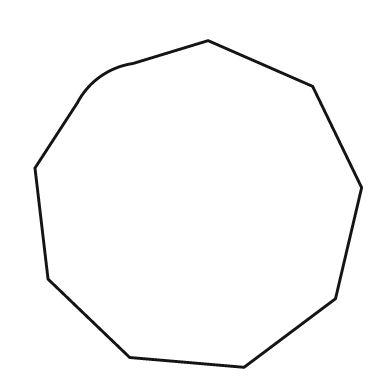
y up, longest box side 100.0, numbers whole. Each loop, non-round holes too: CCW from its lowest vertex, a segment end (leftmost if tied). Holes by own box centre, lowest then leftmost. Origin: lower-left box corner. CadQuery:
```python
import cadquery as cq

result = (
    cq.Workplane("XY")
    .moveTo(64.0, 0.0)
    .lineTo(92.0, 21.0)
    .lineTo(100.0, 55.0)
    .lineTo(85.0, 86.0)
    .lineTo(53.0, 100.0)
    .lineTo(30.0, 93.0)
    .threePointArc((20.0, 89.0), (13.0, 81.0))
    .lineTo(0.0, 61.0)
    .lineTo(4.0, 27.0)
    .lineTo(29.0, 3.0)
    .close()
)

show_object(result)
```